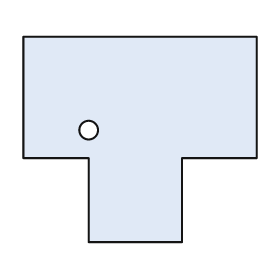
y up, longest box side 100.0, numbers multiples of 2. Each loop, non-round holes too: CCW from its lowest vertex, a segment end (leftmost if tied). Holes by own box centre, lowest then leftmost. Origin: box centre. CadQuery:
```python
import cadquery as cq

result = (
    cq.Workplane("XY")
    .moveTo(-22.0, -44.0)
    .lineTo(18.0, -44.0)
    .lineTo(18.0, -8.0)
    .lineTo(50.0, -8.0)
    .lineTo(50.0, 44.0)
    .lineTo(-50.0, 44.0)
    .lineTo(-50.0, -8.0)
    .lineTo(-22.0, -8.0)
    .close()
    .moveTo(-22.0, 4.0)
    .circle(4.0)
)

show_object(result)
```